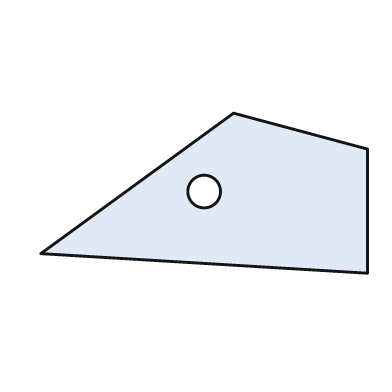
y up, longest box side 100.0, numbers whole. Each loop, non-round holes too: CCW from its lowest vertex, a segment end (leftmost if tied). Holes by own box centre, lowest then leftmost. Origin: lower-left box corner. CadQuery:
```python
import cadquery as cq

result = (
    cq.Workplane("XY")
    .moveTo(100.0, 0.0)
    .lineTo(100.0, 38.0)
    .lineTo(59.0, 49.0)
    .lineTo(0.0, 6.0)
    .close()
    .moveTo(50.0, 25.0)
    .circle(5.0)
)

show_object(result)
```